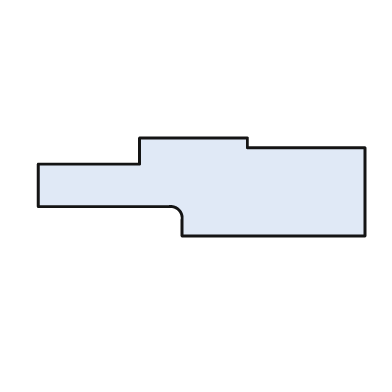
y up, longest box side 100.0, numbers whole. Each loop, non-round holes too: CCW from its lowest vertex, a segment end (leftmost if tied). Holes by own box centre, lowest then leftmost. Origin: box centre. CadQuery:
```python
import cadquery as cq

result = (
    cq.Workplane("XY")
    .moveTo(-6.0, -15.0)
    .lineTo(50.0, -15.0)
    .lineTo(50.0, 12.0)
    .lineTo(14.0, 12.0)
    .lineTo(14.0, 15.0)
    .lineTo(-19.0, 15.0)
    .lineTo(-19.0, 7.0)
    .lineTo(-50.0, 7.0)
    .lineTo(-50.0, -6.0)
    .lineTo(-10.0, -6.0)
    .threePointArc((-7.0, -7.0), (-6.0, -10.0))
    .close()
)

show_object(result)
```